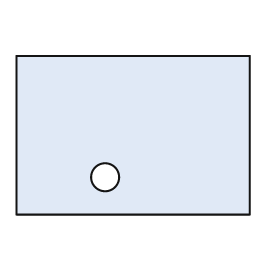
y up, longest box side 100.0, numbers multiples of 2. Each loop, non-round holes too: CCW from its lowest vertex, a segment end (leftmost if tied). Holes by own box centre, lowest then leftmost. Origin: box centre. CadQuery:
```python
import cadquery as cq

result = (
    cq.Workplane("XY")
    .moveTo(-50.0, -34.0)
    .lineTo(50.0, -34.0)
    .lineTo(50.0, 34.0)
    .lineTo(-50.0, 34.0)
    .close()
    .moveTo(-12.0, -18.0)
    .circle(6.0)
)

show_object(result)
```